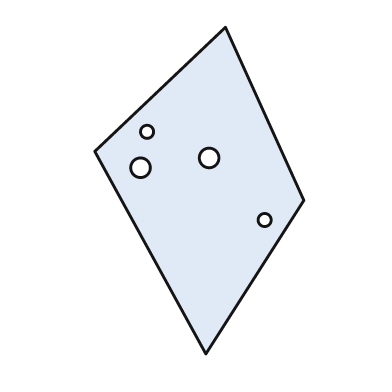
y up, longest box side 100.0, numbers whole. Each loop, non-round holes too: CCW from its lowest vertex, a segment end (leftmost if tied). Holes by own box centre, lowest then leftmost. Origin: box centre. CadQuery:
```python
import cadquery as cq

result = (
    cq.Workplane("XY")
    .moveTo(2.0, -50.0)
    .lineTo(32.0, -3.0)
    .lineTo(8.0, 50.0)
    .lineTo(-32.0, 12.0)
    .close()
    .moveTo(20.0, -9.0)
    .circle(2.0)
    .moveTo(-18.0, 7.0)
    .circle(3.0)
    .moveTo(3.0, 10.0)
    .circle(3.0)
    .moveTo(-16.0, 18.0)
    .circle(2.0)
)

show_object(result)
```